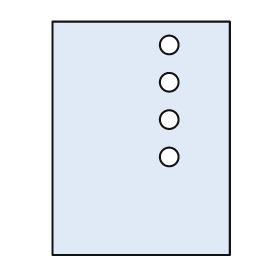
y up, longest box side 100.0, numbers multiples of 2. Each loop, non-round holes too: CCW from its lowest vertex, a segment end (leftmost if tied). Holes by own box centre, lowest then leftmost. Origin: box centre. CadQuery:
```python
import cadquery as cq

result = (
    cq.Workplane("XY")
    .moveTo(-38.0, -50.0)
    .lineTo(38.0, -50.0)
    .lineTo(38.0, 50.0)
    .lineTo(-38.0, 50.0)
    .close()
    .moveTo(12.0, -8.0)
    .circle(4.0)
    .moveTo(12.0, 8.0)
    .circle(4.0)
    .moveTo(12.0, 24.0)
    .circle(4.0)
    .moveTo(12.0, 40.0)
    .circle(4.0)
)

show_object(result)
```